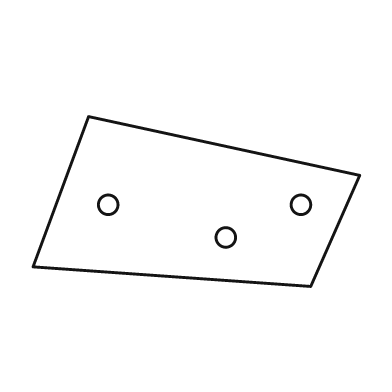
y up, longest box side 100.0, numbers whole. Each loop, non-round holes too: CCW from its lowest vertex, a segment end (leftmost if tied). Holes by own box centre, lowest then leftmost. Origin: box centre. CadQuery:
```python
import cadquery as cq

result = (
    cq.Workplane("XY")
    .moveTo(35.0, -26.0)
    .lineTo(50.0, 8.0)
    .lineTo(-33.0, 26.0)
    .lineTo(-50.0, -20.0)
    .close()
    .moveTo(9.0, -11.0)
    .circle(3.0)
    .moveTo(-27.0, -1.0)
    .circle(3.0)
    .moveTo(32.0, -1.0)
    .circle(3.0)
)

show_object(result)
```